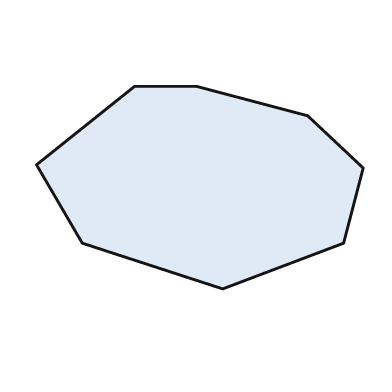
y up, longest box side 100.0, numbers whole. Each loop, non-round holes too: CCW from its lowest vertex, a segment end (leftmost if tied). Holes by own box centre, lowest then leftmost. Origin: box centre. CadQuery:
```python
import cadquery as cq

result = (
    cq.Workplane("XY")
    .moveTo(7.0, -31.0)
    .lineTo(44.0, -17.0)
    .lineTo(50.0, 6.0)
    .lineTo(33.0, 22.0)
    .lineTo(-1.0, 31.0)
    .lineTo(-20.0, 31.0)
    .lineTo(-50.0, 7.0)
    .lineTo(-36.0, -17.0)
    .close()
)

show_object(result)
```